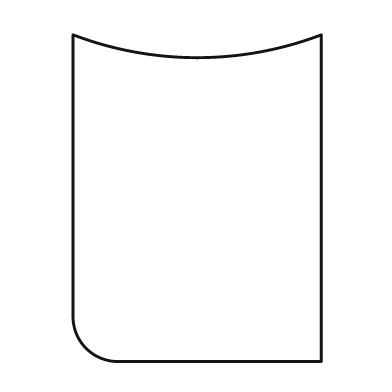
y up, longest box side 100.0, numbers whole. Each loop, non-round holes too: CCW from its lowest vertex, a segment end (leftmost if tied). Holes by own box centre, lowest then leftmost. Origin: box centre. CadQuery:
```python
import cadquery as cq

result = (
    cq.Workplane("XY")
    .moveTo(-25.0, -50.0)
    .lineTo(38.0, -50.0)
    .lineTo(38.0, 50.0)
    .threePointArc((0.0, 43.0), (-38.0, 50.0))
    .lineTo(-38.0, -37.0)
    .threePointArc((-34.0, -46.0), (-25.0, -50.0))
    .close()
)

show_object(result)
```